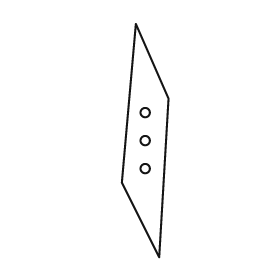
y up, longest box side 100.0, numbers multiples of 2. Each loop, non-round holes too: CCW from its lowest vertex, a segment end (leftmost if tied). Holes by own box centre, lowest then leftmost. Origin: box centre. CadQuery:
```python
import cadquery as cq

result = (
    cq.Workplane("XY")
    .moveTo(6.0, -50.0)
    .lineTo(10.0, 18.0)
    .lineTo(-4.0, 50.0)
    .lineTo(-10.0, -18.0)
    .close()
    .moveTo(0.0, -12.0)
    .circle(2.0)
    .moveTo(0.0, 0.0)
    .circle(2.0)
    .moveTo(0.0, 12.0)
    .circle(2.0)
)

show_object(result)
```